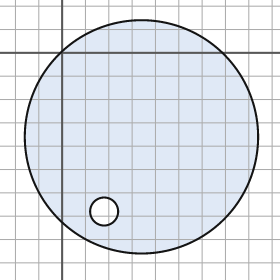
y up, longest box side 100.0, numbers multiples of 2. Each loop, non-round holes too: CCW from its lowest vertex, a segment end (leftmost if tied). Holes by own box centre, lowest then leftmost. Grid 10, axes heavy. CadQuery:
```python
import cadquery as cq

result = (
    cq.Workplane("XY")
    .moveTo(34.0, -36.0)
    .circle(50.0)
    .moveTo(18.0, -68.0)
    .circle(6.0)
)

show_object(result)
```